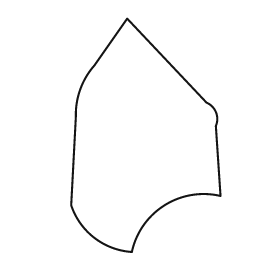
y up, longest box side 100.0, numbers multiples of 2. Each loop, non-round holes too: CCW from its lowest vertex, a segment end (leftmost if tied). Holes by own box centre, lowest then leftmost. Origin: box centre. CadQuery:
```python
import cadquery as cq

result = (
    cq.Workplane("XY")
    .moveTo(-6.0, -50.0)
    .threePointArc((8.0, -30.0), (32.0, -26.0))
    .lineTo(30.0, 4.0)
    .threePointArc((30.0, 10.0), (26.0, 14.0))
    .lineTo(-8.0, 50.0)
    .lineTo(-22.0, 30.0)
    .threePointArc((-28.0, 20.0), (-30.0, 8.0))
    .lineTo(-32.0, -30.0)
    .threePointArc((-22.0, -44.0), (-6.0, -50.0))
    .close()
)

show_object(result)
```